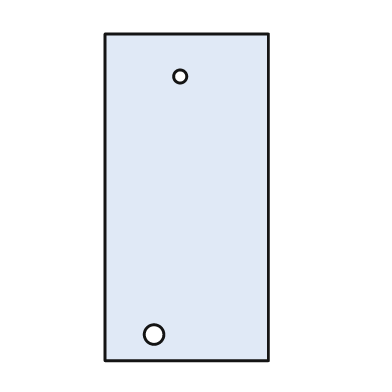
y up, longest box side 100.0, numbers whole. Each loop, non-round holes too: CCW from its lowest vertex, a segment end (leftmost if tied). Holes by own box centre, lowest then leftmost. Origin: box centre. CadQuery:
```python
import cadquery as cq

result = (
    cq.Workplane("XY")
    .moveTo(-25.0, -50.0)
    .lineTo(25.0, -50.0)
    .lineTo(25.0, 50.0)
    .lineTo(-25.0, 50.0)
    .close()
    .moveTo(-10.0, -42.0)
    .circle(3.0)
    .moveTo(-2.0, 37.0)
    .circle(2.0)
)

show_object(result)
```